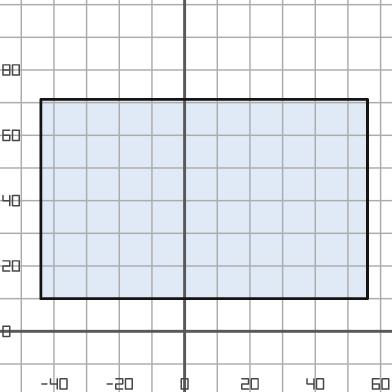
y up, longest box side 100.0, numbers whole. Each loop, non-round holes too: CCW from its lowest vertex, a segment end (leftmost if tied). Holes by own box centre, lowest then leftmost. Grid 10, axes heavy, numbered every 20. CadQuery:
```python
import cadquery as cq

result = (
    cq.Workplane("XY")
    .moveTo(-44.0, 10.0)
    .lineTo(56.0, 10.0)
    .lineTo(56.0, 71.0)
    .lineTo(-44.0, 71.0)
    .close()
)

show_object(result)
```